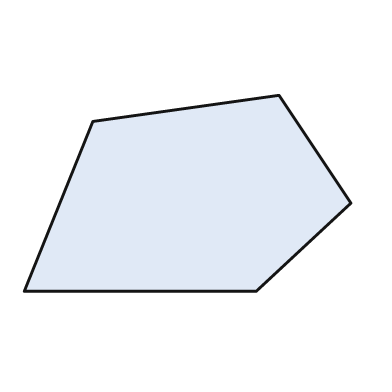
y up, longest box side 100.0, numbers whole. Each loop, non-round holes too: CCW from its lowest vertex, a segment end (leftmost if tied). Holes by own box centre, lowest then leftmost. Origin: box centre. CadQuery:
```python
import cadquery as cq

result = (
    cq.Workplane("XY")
    .moveTo(-50.0, -30.0)
    .lineTo(21.0, -30.0)
    .lineTo(50.0, -3.0)
    .lineTo(28.0, 30.0)
    .lineTo(-29.0, 22.0)
    .close()
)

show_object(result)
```